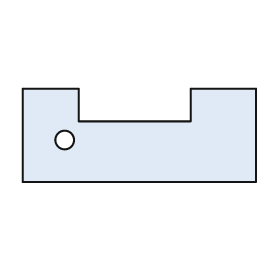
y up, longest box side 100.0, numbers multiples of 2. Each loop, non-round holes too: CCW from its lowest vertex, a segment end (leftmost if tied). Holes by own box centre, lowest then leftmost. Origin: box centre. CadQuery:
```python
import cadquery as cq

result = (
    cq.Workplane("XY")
    .moveTo(-50.0, -20.0)
    .lineTo(50.0, -20.0)
    .lineTo(50.0, 20.0)
    .lineTo(22.0, 20.0)
    .lineTo(22.0, 6.0)
    .lineTo(-26.0, 6.0)
    .lineTo(-26.0, 20.0)
    .lineTo(-50.0, 20.0)
    .close()
    .moveTo(-32.0, -2.0)
    .circle(4.0)
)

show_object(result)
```